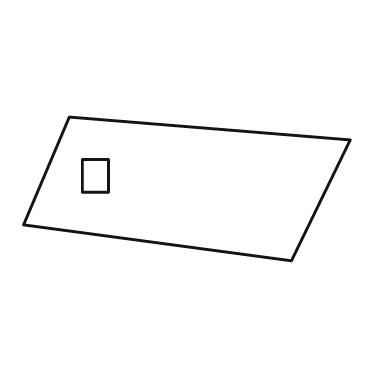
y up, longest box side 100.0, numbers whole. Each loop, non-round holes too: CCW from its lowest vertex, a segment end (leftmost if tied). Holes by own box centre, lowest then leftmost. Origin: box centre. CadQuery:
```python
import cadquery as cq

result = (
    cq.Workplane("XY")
    .moveTo(32.0, -22.0)
    .lineTo(50.0, 15.0)
    .lineTo(-36.0, 22.0)
    .lineTo(-50.0, -11.0)
    .close()
    .moveTo(-32.0, -1.0)
    .lineTo(-24.0, -1.0)
    .lineTo(-24.0, 9.0)
    .lineTo(-32.0, 9.0)
    .close()
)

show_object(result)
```